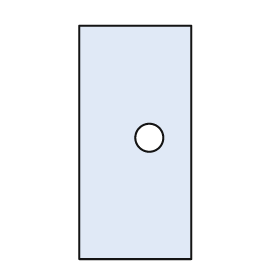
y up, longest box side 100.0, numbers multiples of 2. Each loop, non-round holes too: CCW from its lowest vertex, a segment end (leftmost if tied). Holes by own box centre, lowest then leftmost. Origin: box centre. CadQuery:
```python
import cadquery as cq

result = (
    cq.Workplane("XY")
    .moveTo(-24.0, -50.0)
    .lineTo(24.0, -50.0)
    .lineTo(24.0, 50.0)
    .lineTo(-24.0, 50.0)
    .close()
    .moveTo(6.0, 2.0)
    .circle(6.0)
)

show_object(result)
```